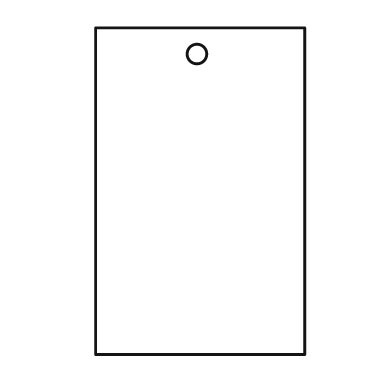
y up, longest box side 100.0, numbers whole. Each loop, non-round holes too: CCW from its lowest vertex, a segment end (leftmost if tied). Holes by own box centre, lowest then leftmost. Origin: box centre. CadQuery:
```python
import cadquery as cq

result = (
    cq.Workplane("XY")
    .moveTo(-32.0, -50.0)
    .lineTo(32.0, -50.0)
    .lineTo(32.0, 50.0)
    .lineTo(-32.0, 50.0)
    .close()
    .moveTo(-1.0, 42.0)
    .circle(3.0)
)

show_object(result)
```